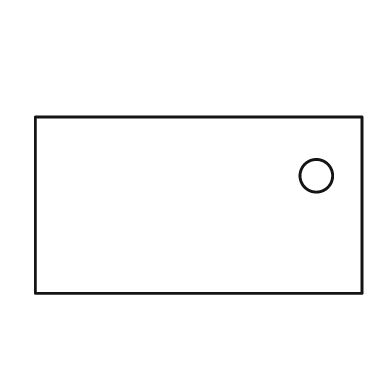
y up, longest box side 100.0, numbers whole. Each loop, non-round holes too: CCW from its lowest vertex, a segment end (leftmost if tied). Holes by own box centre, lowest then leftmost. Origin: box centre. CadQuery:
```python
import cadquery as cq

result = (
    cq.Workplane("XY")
    .moveTo(-50.0, -27.0)
    .lineTo(50.0, -27.0)
    .lineTo(50.0, 27.0)
    .lineTo(-50.0, 27.0)
    .close()
    .moveTo(36.0, 9.0)
    .circle(5.0)
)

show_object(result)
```